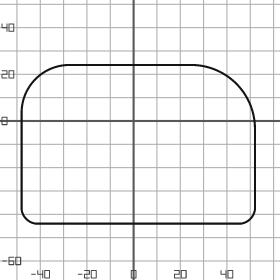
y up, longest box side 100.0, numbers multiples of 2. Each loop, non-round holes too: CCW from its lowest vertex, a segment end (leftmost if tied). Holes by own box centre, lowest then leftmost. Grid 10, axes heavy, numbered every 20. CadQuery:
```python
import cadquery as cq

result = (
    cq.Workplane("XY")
    .moveTo(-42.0, -44.0)
    .lineTo(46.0, -44.0)
    .threePointArc((50.0, -42.0), (52.0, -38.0))
    .lineTo(52.0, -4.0)
    .threePointArc((44.0, 16.0), (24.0, 24.0))
    .lineTo(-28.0, 24.0)
    .threePointArc((-42.0, 18.0), (-48.0, 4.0))
    .lineTo(-48.0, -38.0)
    .threePointArc((-46.0, -42.0), (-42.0, -44.0))
    .close()
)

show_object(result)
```